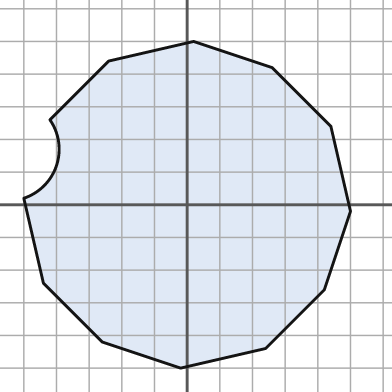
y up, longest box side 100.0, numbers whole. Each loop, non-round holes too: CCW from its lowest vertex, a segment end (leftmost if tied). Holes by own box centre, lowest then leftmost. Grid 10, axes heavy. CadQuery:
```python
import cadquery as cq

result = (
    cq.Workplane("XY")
    .moveTo(-2.0, -50.0)
    .lineTo(24.0, -44.0)
    .lineTo(42.0, -26.0)
    .lineTo(50.0, -2.0)
    .lineTo(44.0, 24.0)
    .lineTo(26.0, 42.0)
    .lineTo(2.0, 50.0)
    .lineTo(-24.0, 44.0)
    .lineTo(-42.0, 26.0)
    .threePointArc((-40.0, 12.0), (-50.0, 2.0))
    .lineTo(-44.0, -24.0)
    .lineTo(-26.0, -42.0)
    .close()
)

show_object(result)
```